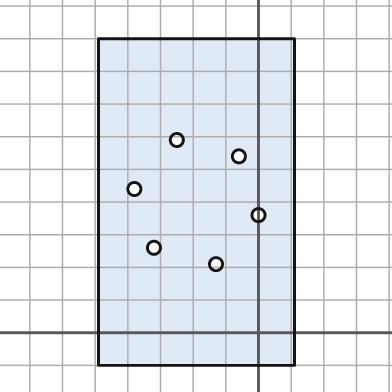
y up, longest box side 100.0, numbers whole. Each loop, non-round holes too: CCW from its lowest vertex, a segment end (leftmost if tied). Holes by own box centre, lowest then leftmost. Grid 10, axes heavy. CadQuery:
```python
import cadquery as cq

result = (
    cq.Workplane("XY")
    .moveTo(-49.0, -10.0)
    .lineTo(11.0, -10.0)
    .lineTo(11.0, 90.0)
    .lineTo(-49.0, 90.0)
    .close()
    .moveTo(-13.0, 21.0)
    .circle(2.0)
    .moveTo(-32.0, 26.0)
    .circle(2.0)
    .moveTo(0.0, 36.0)
    .circle(2.0)
    .moveTo(-38.0, 44.0)
    .circle(2.0)
    .moveTo(-6.0, 54.0)
    .circle(2.0)
    .moveTo(-25.0, 59.0)
    .circle(2.0)
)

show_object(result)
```